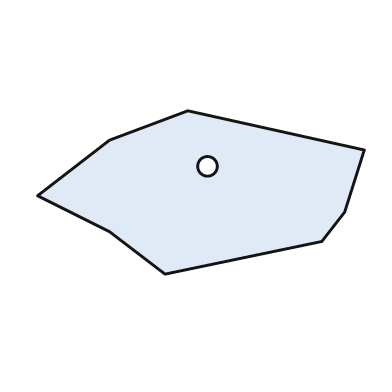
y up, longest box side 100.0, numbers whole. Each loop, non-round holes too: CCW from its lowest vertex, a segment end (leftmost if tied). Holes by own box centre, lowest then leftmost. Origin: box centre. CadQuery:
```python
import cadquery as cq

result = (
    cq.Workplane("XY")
    .moveTo(-11.0, -25.0)
    .lineTo(37.0, -15.0)
    .lineTo(44.0, -6.0)
    .lineTo(50.0, 13.0)
    .lineTo(-4.0, 25.0)
    .lineTo(-28.0, 16.0)
    .lineTo(-50.0, -1.0)
    .lineTo(-28.0, -12.0)
    .close()
    .moveTo(2.0, 8.0)
    .circle(3.0)
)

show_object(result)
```